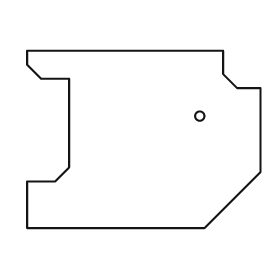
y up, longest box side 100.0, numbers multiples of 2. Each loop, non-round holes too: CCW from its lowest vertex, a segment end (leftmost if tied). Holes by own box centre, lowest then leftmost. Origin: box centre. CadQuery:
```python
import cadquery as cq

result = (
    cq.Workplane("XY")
    .moveTo(-50.0, -38.0)
    .lineTo(26.0, -38.0)
    .lineTo(50.0, -14.0)
    .lineTo(50.0, 22.0)
    .lineTo(40.0, 22.0)
    .lineTo(34.0, 28.0)
    .lineTo(34.0, 38.0)
    .lineTo(-50.0, 38.0)
    .lineTo(-50.0, 32.0)
    .lineTo(-44.0, 26.0)
    .lineTo(-32.0, 26.0)
    .lineTo(-32.0, -12.0)
    .lineTo(-38.0, -18.0)
    .lineTo(-50.0, -18.0)
    .close()
    .moveTo(24.0, 10.0)
    .circle(2.0)
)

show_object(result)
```